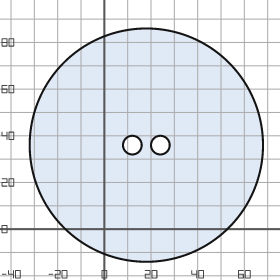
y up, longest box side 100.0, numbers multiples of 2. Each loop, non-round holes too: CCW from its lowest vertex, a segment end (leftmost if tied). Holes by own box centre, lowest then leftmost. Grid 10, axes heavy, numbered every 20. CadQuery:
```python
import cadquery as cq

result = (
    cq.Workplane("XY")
    .moveTo(18.0, 36.0)
    .circle(50.0)
    .moveTo(12.0, 36.0)
    .circle(4.0)
    .moveTo(24.0, 36.0)
    .circle(4.0)
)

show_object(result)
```